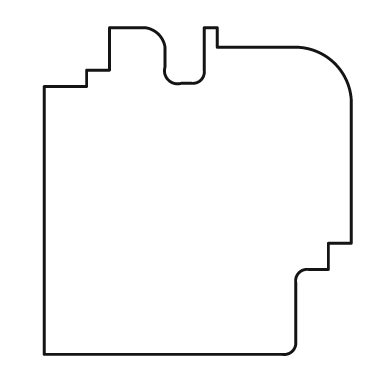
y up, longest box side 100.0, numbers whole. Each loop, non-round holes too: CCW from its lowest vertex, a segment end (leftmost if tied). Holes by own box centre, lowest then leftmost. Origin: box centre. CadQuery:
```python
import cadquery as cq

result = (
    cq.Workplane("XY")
    .moveTo(-47.0, -50.0)
    .lineTo(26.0, -50.0)
    .threePointArc((29.0, -49.0), (30.0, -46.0))
    .lineTo(30.0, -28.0)
    .threePointArc((31.0, -25.0), (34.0, -24.0))
    .lineTo(40.0, -24.0)
    .lineTo(40.0, -16.0)
    .lineTo(47.0, -16.0)
    .lineTo(47.0, 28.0)
    .threePointArc((42.0, 39.0), (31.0, 44.0))
    .lineTo(6.0, 44.0)
    .lineTo(6.0, 50.0)
    .lineTo(2.0, 50.0)
    .lineTo(2.0, 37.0)
    .threePointArc((1.0, 34.0), (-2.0, 33.0))
    .lineTo(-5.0, 33.0)
    .threePointArc((-9.0, 34.0), (-10.0, 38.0))
    .lineTo(-10.0, 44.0)
    .threePointArc((-12.0, 48.0), (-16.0, 50.0))
    .lineTo(-27.0, 50.0)
    .lineTo(-27.0, 37.0)
    .lineTo(-34.0, 37.0)
    .lineTo(-34.0, 32.0)
    .lineTo(-47.0, 32.0)
    .close()
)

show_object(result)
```